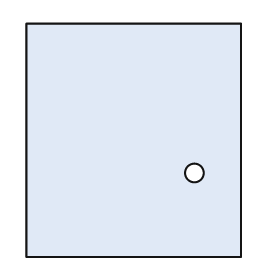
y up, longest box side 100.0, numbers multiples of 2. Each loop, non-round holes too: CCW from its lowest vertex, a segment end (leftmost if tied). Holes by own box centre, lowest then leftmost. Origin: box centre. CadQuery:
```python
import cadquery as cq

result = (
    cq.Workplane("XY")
    .moveTo(-46.0, -50.0)
    .lineTo(46.0, -50.0)
    .lineTo(46.0, 50.0)
    .lineTo(-46.0, 50.0)
    .close()
    .moveTo(26.0, -14.0)
    .circle(4.0)
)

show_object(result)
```